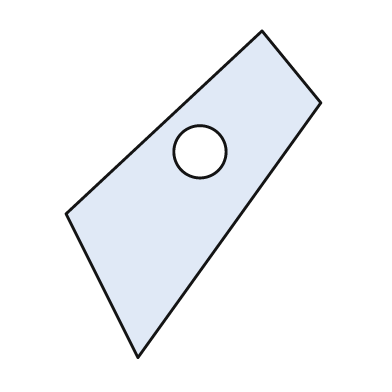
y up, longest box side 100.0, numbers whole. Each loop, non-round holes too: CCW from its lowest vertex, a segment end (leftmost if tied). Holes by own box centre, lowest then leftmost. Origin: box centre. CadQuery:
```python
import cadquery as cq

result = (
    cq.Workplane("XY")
    .moveTo(-17.0, -50.0)
    .lineTo(39.0, 28.0)
    .lineTo(21.0, 50.0)
    .lineTo(-39.0, -6.0)
    .close()
    .moveTo(2.0, 13.0)
    .circle(8.0)
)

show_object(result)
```